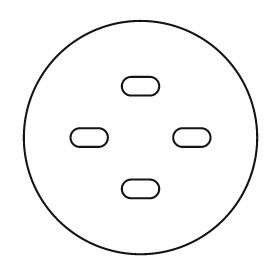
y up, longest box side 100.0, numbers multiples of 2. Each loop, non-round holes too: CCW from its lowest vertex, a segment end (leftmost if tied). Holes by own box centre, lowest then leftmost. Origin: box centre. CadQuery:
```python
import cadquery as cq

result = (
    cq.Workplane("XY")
    .moveTo(0.0, 0.0)
    .circle(50.0)
    .moveTo(-4.0, -26.0)
    .lineTo(4.0, -26.0)
    .threePointArc((8.0, -22.0), (4.0, -18.0))
    .lineTo(-4.0, -18.0)
    .threePointArc((-8.0, -22.0), (-4.0, -26.0))
    .close()
    .moveTo(-26.0, -4.0)
    .lineTo(-18.0, -4.0)
    .threePointArc((-14.0, 0.0), (-18.0, 4.0))
    .lineTo(-26.0, 4.0)
    .threePointArc((-30.0, 0.0), (-26.0, -4.0))
    .close()
    .moveTo(18.0, -4.0)
    .lineTo(26.0, -4.0)
    .threePointArc((30.0, 0.0), (26.0, 4.0))
    .lineTo(18.0, 4.0)
    .threePointArc((14.0, 0.0), (18.0, -4.0))
    .close()
    .moveTo(-4.0, 18.0)
    .lineTo(4.0, 18.0)
    .threePointArc((8.0, 22.0), (4.0, 26.0))
    .lineTo(-4.0, 26.0)
    .threePointArc((-8.0, 22.0), (-4.0, 18.0))
    .close()
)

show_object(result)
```